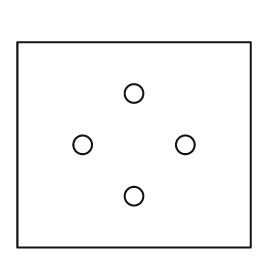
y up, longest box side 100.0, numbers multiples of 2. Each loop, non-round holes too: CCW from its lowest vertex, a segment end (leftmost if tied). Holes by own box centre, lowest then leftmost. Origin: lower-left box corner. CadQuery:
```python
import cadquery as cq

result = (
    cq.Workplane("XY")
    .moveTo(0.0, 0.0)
    .lineTo(100.0, 0.0)
    .lineTo(100.0, 88.0)
    .lineTo(0.0, 88.0)
    .close()
    .moveTo(50.0, 22.0)
    .circle(4.0)
    .moveTo(28.0, 44.0)
    .circle(4.0)
    .moveTo(72.0, 44.0)
    .circle(4.0)
    .moveTo(50.0, 66.0)
    .circle(4.0)
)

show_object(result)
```